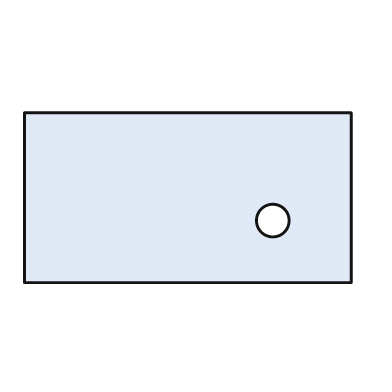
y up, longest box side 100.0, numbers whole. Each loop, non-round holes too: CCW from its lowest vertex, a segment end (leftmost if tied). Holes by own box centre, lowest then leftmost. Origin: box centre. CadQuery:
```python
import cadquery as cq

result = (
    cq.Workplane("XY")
    .moveTo(-50.0, -26.0)
    .lineTo(50.0, -26.0)
    .lineTo(50.0, 26.0)
    .lineTo(-50.0, 26.0)
    .close()
    .moveTo(26.0, -7.0)
    .circle(5.0)
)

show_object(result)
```